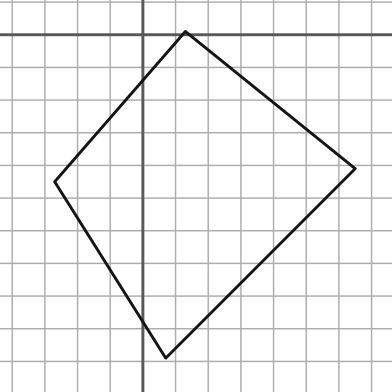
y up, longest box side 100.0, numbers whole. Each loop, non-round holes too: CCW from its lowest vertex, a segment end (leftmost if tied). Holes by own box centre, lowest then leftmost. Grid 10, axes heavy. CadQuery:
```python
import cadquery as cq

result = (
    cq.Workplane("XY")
    .moveTo(7.0, -99.0)
    .lineTo(65.0, -41.0)
    .lineTo(13.0, 1.0)
    .lineTo(-27.0, -45.0)
    .close()
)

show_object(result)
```